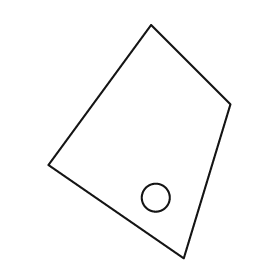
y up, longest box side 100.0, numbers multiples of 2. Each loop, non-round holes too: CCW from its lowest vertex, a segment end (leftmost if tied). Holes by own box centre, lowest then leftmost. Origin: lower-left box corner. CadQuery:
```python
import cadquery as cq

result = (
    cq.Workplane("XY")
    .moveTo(58.0, 0.0)
    .lineTo(78.0, 66.0)
    .lineTo(44.0, 100.0)
    .lineTo(0.0, 40.0)
    .close()
    .moveTo(46.0, 26.0)
    .circle(6.0)
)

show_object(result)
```